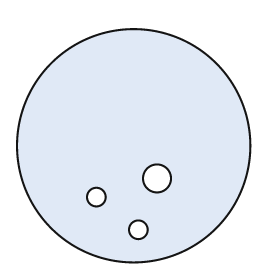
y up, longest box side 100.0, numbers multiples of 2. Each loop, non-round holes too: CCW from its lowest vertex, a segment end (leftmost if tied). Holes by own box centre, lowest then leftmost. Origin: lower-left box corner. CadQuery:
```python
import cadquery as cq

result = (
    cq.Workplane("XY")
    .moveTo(50.0, 50.0)
    .circle(50.0)
    .moveTo(52.0, 14.0)
    .circle(4.0)
    .moveTo(34.0, 28.0)
    .circle(4.0)
    .moveTo(60.0, 36.0)
    .circle(6.0)
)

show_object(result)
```